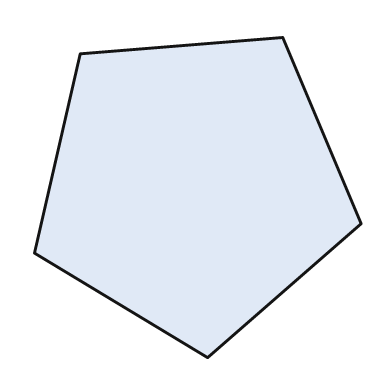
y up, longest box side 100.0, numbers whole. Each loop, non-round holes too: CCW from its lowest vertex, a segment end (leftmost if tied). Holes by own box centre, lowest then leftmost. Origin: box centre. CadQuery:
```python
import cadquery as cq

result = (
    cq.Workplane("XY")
    .moveTo(3.0, -49.0)
    .lineTo(50.0, -8.0)
    .lineTo(26.0, 49.0)
    .lineTo(-36.0, 44.0)
    .lineTo(-50.0, -17.0)
    .close()
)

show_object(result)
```